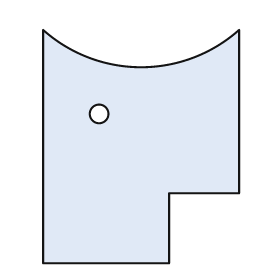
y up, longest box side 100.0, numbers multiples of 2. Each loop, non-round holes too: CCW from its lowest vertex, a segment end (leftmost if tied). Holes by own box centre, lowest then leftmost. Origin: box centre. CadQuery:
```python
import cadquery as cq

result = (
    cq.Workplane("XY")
    .moveTo(-42.0, -50.0)
    .lineTo(12.0, -50.0)
    .lineTo(12.0, -20.0)
    .lineTo(42.0, -20.0)
    .lineTo(42.0, 50.0)
    .threePointArc((0.0, 34.0), (-42.0, 50.0))
    .close()
    .moveTo(-18.0, 14.0)
    .circle(4.0)
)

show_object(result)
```